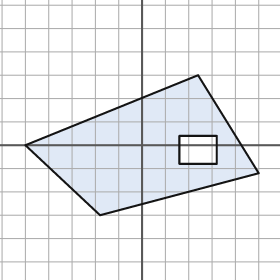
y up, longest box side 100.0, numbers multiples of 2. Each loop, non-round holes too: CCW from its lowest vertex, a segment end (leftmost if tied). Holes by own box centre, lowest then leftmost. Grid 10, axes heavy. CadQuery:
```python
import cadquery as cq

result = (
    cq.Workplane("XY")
    .moveTo(-18.0, -30.0)
    .lineTo(50.0, -12.0)
    .lineTo(24.0, 30.0)
    .lineTo(-50.0, 0.0)
    .close()
    .moveTo(16.0, -8.0)
    .lineTo(32.0, -8.0)
    .lineTo(32.0, 4.0)
    .lineTo(16.0, 4.0)
    .close()
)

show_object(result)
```